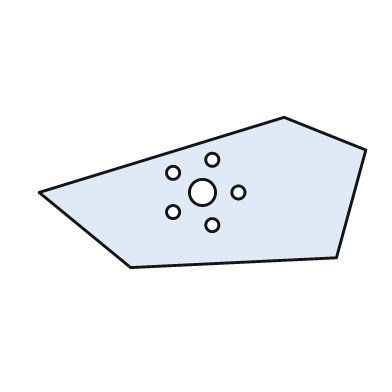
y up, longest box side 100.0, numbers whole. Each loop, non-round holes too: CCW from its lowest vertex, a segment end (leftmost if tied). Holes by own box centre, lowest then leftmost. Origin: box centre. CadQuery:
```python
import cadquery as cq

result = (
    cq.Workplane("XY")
    .moveTo(-22.0, -23.0)
    .lineTo(41.0, -20.0)
    .lineTo(50.0, 13.0)
    .lineTo(25.0, 23.0)
    .lineTo(-50.0, 0.0)
    .close()
    .moveTo(3.0, -10.0)
    .circle(2.0)
    .moveTo(-9.0, -6.0)
    .circle(2.0)
    .moveTo(0.0, 0.0)
    .circle(4.0)
    .moveTo(11.0, 0.0)
    .circle(2.0)
    .moveTo(-9.0, 6.0)
    .circle(2.0)
    .moveTo(3.0, 10.0)
    .circle(2.0)
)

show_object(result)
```